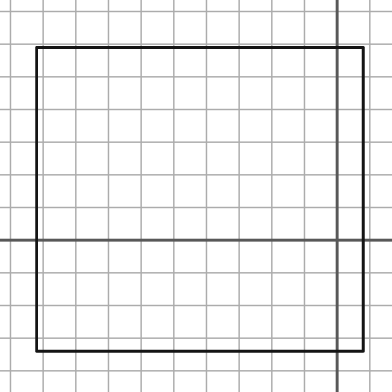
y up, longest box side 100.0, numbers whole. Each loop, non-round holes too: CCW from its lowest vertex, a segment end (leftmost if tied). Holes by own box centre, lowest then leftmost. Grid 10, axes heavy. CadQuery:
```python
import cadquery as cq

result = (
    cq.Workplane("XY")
    .moveTo(-92.0, -34.0)
    .lineTo(8.0, -34.0)
    .lineTo(8.0, 59.0)
    .lineTo(-92.0, 59.0)
    .close()
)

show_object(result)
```